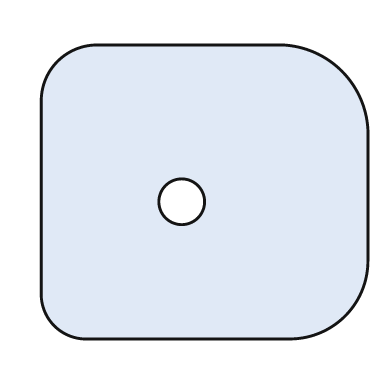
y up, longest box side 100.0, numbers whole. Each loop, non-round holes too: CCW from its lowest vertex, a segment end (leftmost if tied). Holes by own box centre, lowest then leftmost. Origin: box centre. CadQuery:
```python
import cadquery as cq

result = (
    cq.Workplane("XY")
    .moveTo(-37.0, -45.0)
    .lineTo(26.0, -45.0)
    .threePointArc((43.0, -38.0), (50.0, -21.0))
    .lineTo(50.0, 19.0)
    .threePointArc((42.0, 37.0), (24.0, 45.0))
    .lineTo(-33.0, 45.0)
    .threePointArc((-45.0, 40.0), (-50.0, 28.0))
    .lineTo(-50.0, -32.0)
    .threePointArc((-46.0, -41.0), (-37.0, -45.0))
    .close()
    .moveTo(-7.0, -3.0)
    .circle(7.0)
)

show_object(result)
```